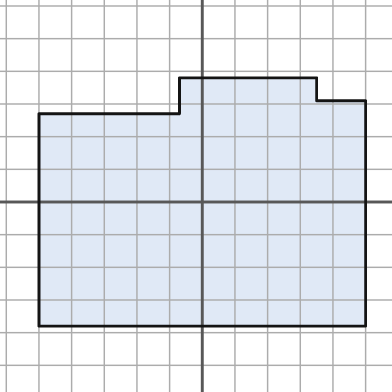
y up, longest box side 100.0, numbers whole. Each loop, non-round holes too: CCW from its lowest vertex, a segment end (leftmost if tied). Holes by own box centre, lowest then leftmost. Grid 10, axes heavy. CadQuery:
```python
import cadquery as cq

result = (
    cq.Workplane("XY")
    .moveTo(-50.0, -38.0)
    .lineTo(50.0, -38.0)
    .lineTo(50.0, 31.0)
    .lineTo(35.0, 31.0)
    .lineTo(35.0, 38.0)
    .lineTo(-7.0, 38.0)
    .lineTo(-7.0, 27.0)
    .lineTo(-50.0, 27.0)
    .close()
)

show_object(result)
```